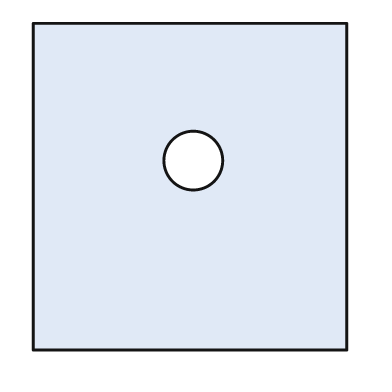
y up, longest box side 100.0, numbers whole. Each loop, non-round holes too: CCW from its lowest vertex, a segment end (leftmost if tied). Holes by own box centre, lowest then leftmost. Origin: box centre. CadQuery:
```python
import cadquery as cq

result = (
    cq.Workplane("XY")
    .moveTo(-48.0, -50.0)
    .lineTo(48.0, -50.0)
    .lineTo(48.0, 50.0)
    .lineTo(-48.0, 50.0)
    .close()
    .moveTo(1.0, 8.0)
    .circle(9.0)
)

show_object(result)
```